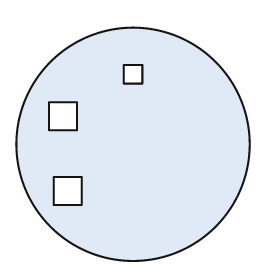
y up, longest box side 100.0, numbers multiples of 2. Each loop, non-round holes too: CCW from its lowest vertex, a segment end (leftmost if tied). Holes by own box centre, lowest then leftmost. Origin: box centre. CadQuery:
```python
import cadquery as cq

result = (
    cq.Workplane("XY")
    .moveTo(0.0, 0.0)
    .circle(50.0)
    .moveTo(-34.0, -26.0)
    .lineTo(-22.0, -26.0)
    .lineTo(-22.0, -14.0)
    .lineTo(-34.0, -14.0)
    .close()
    .moveTo(-36.0, 6.0)
    .lineTo(-24.0, 6.0)
    .lineTo(-24.0, 18.0)
    .lineTo(-36.0, 18.0)
    .close()
    .moveTo(-4.0, 26.0)
    .lineTo(4.0, 26.0)
    .lineTo(4.0, 34.0)
    .lineTo(-4.0, 34.0)
    .close()
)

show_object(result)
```